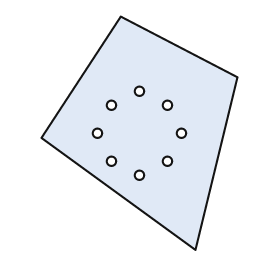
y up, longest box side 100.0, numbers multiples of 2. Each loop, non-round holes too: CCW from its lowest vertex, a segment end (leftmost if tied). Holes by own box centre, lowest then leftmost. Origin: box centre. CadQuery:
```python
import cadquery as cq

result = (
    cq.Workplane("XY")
    .moveTo(24.0, -50.0)
    .lineTo(42.0, 24.0)
    .lineTo(-8.0, 50.0)
    .lineTo(-42.0, -2.0)
    .close()
    .moveTo(0.0, -18.0)
    .circle(2.0)
    .moveTo(-12.0, -12.0)
    .circle(2.0)
    .moveTo(12.0, -12.0)
    .circle(2.0)
    .moveTo(-18.0, 0.0)
    .circle(2.0)
    .moveTo(18.0, 0.0)
    .circle(2.0)
    .moveTo(-12.0, 12.0)
    .circle(2.0)
    .moveTo(12.0, 12.0)
    .circle(2.0)
    .moveTo(0.0, 18.0)
    .circle(2.0)
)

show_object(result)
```